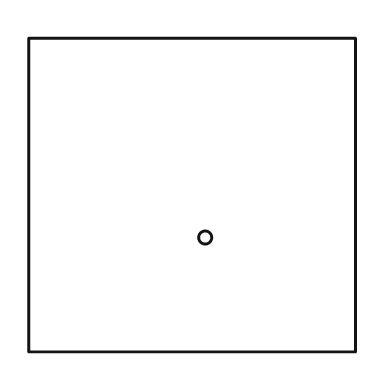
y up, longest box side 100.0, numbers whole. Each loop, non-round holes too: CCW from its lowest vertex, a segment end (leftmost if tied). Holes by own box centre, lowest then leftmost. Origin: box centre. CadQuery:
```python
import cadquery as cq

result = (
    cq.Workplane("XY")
    .moveTo(-50.0, -48.0)
    .lineTo(50.0, -48.0)
    .lineTo(50.0, 48.0)
    .lineTo(-50.0, 48.0)
    .close()
    .moveTo(4.0, -13.0)
    .circle(2.0)
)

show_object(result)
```